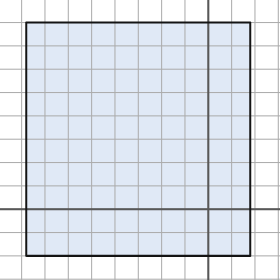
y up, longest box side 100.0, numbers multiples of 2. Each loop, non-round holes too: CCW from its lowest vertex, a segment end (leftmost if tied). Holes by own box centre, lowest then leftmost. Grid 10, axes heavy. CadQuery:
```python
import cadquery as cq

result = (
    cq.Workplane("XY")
    .moveTo(-78.0, -20.0)
    .lineTo(18.0, -20.0)
    .lineTo(18.0, 80.0)
    .lineTo(-78.0, 80.0)
    .close()
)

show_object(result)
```